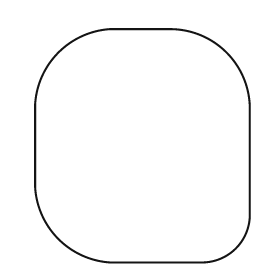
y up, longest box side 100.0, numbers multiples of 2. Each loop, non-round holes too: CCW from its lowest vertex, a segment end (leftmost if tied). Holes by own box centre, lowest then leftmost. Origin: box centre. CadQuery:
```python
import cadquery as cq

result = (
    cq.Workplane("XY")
    .moveTo(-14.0, -50.0)
    .lineTo(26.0, -50.0)
    .threePointArc((40.0, -44.0), (46.0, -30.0))
    .lineTo(46.0, 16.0)
    .threePointArc((36.0, 40.0), (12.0, 50.0))
    .lineTo(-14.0, 50.0)
    .threePointArc((-36.0, 40.0), (-46.0, 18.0))
    .lineTo(-46.0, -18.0)
    .threePointArc((-36.0, -40.0), (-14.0, -50.0))
    .close()
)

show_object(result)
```